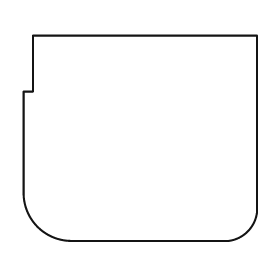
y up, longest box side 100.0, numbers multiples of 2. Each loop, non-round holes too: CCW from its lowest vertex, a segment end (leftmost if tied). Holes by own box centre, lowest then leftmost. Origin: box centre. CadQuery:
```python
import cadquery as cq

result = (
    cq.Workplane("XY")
    .moveTo(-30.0, -44.0)
    .lineTo(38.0, -44.0)
    .threePointArc((46.0, -40.0), (50.0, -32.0))
    .lineTo(50.0, 44.0)
    .lineTo(-46.0, 44.0)
    .lineTo(-46.0, 20.0)
    .lineTo(-50.0, 20.0)
    .lineTo(-50.0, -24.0)
    .threePointArc((-44.0, -38.0), (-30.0, -44.0))
    .close()
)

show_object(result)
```